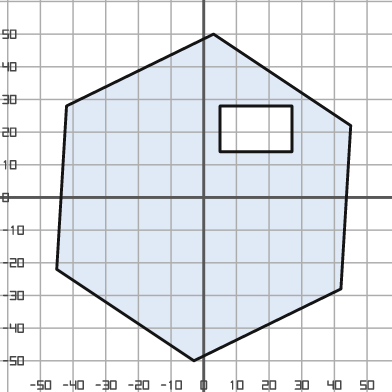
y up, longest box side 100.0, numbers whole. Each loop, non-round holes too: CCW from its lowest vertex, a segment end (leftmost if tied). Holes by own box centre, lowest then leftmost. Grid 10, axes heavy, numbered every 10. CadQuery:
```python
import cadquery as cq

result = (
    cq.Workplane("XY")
    .moveTo(-3.0, -50.0)
    .lineTo(42.0, -28.0)
    .lineTo(45.0, 22.0)
    .lineTo(3.0, 50.0)
    .lineTo(-42.0, 28.0)
    .lineTo(-45.0, -22.0)
    .close()
    .moveTo(5.0, 14.0)
    .lineTo(27.0, 14.0)
    .lineTo(27.0, 28.0)
    .lineTo(5.0, 28.0)
    .close()
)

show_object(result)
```